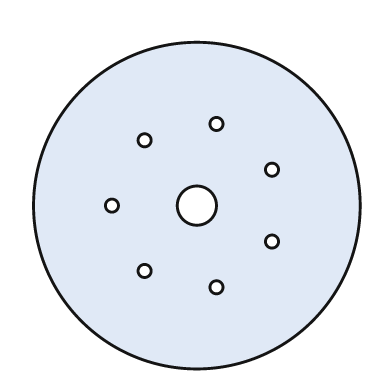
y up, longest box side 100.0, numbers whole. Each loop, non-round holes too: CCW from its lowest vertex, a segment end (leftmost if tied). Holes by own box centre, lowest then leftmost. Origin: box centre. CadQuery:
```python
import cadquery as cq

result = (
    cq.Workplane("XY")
    .moveTo(0.0, 0.0)
    .circle(50.0)
    .moveTo(6.0, -25.0)
    .circle(2.0)
    .moveTo(-16.0, -20.0)
    .circle(2.0)
    .moveTo(23.0, -11.0)
    .circle(2.0)
    .moveTo(-26.0, 0.0)
    .circle(2.0)
    .moveTo(0.0, 0.0)
    .circle(6.0)
    .moveTo(23.0, 11.0)
    .circle(2.0)
    .moveTo(-16.0, 20.0)
    .circle(2.0)
    .moveTo(6.0, 25.0)
    .circle(2.0)
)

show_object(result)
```